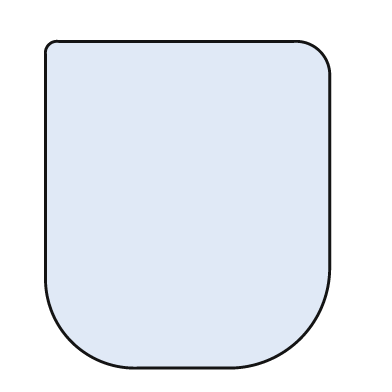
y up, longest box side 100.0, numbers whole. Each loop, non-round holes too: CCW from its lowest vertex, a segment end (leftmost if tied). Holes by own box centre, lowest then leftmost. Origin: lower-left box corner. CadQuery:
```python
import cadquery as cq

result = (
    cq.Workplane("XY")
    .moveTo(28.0, 0.0)
    .lineTo(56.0, 0.0)
    .threePointArc((78.0, 9.0), (87.0, 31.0))
    .lineTo(87.0, 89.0)
    .threePointArc((84.0, 97.0), (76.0, 100.0))
    .lineTo(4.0, 100.0)
    .threePointArc((1.0, 99.0), (0.0, 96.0))
    .lineTo(0.0, 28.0)
    .threePointArc((8.0, 8.0), (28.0, 0.0))
    .close()
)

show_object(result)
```